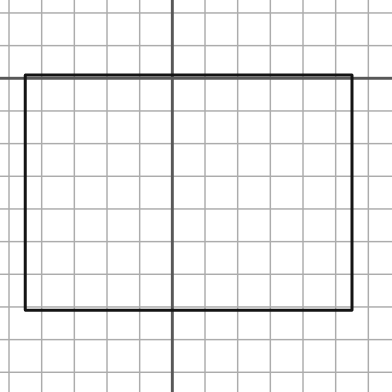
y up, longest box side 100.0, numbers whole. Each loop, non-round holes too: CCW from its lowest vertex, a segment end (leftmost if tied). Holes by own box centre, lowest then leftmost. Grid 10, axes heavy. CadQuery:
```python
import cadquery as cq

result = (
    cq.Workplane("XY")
    .moveTo(-45.0, -71.0)
    .lineTo(55.0, -71.0)
    .lineTo(55.0, 1.0)
    .lineTo(-45.0, 1.0)
    .close()
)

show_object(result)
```